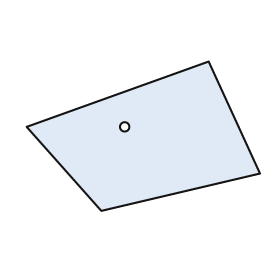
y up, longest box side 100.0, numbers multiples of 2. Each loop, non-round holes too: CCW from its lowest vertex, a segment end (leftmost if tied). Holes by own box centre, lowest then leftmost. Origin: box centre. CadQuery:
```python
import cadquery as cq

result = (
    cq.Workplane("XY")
    .moveTo(-18.0, -32.0)
    .lineTo(50.0, -16.0)
    .lineTo(28.0, 32.0)
    .lineTo(-50.0, 4.0)
    .close()
    .moveTo(-8.0, 4.0)
    .circle(2.0)
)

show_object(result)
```